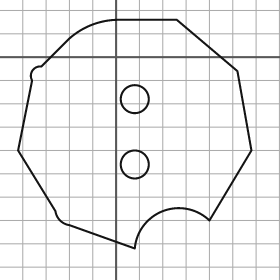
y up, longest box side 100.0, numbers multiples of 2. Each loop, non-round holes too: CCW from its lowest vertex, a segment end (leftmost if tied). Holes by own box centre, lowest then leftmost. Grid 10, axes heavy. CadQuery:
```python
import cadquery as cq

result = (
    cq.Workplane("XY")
    .moveTo(8.0, -82.0)
    .threePointArc((20.0, -66.0), (40.0, -70.0))
    .lineTo(58.0, -40.0)
    .lineTo(52.0, -6.0)
    .lineTo(26.0, 16.0)
    .lineTo(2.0, 16.0)
    .threePointArc((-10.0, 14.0), (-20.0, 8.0))
    .lineTo(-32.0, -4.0)
    .threePointArc((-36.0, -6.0), (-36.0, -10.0))
    .lineTo(-42.0, -40.0)
    .lineTo(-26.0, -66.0)
    .threePointArc((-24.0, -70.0), (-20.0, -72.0))
    .close()
    .moveTo(8.0, -46.0)
    .circle(6.0)
    .moveTo(8.0, -18.0)
    .circle(6.0)
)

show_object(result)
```